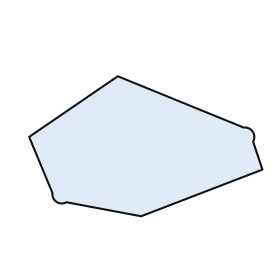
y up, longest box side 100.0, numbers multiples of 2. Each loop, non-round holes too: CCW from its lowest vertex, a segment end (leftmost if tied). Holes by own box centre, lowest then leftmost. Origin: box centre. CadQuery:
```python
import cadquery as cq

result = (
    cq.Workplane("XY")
    .moveTo(-2.0, -30.0)
    .lineTo(50.0, -10.0)
    .lineTo(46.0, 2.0)
    .threePointArc((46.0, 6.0), (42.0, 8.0))
    .lineTo(-12.0, 30.0)
    .lineTo(-50.0, 4.0)
    .lineTo(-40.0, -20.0)
    .threePointArc((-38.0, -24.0), (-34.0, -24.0))
    .close()
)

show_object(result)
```